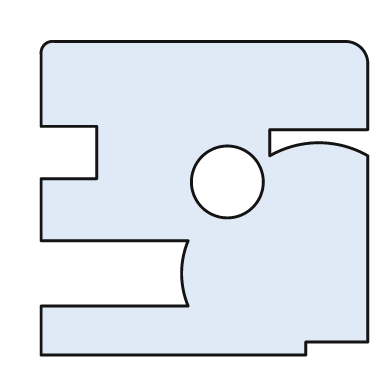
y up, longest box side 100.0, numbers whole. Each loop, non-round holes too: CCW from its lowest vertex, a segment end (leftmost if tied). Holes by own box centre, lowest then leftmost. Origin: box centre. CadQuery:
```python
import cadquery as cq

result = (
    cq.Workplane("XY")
    .moveTo(-50.0, -48.0)
    .lineTo(31.0, -48.0)
    .lineTo(31.0, -44.0)
    .lineTo(50.0, -44.0)
    .lineTo(50.0, 13.0)
    .threePointArc((35.0, 17.0), (20.0, 13.0))
    .lineTo(20.0, 21.0)
    .lineTo(50.0, 21.0)
    .lineTo(50.0, 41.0)
    .threePointArc((48.0, 46.0), (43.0, 48.0))
    .lineTo(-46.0, 48.0)
    .threePointArc((-49.0, 47.0), (-50.0, 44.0))
    .lineTo(-50.0, 22.0)
    .lineTo(-33.0, 22.0)
    .lineTo(-33.0, 6.0)
    .lineTo(-50.0, 6.0)
    .lineTo(-50.0, -13.0)
    .lineTo(-5.0, -13.0)
    .threePointArc((-7.0, -23.0), (-5.0, -33.0))
    .lineTo(-50.0, -33.0)
    .close()
    .moveTo(7.0, 5.0)
    .circle(11.0)
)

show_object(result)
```